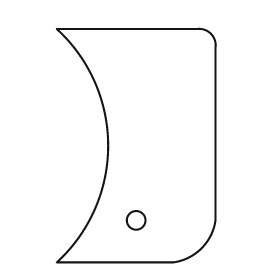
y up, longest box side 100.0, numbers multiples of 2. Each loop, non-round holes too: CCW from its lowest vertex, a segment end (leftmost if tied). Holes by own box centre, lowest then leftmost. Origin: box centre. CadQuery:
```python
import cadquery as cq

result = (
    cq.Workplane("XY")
    .moveTo(-34.0, -50.0)
    .lineTo(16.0, -50.0)
    .threePointArc((28.0, -44.0), (34.0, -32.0))
    .lineTo(34.0, 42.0)
    .threePointArc((32.0, 48.0), (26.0, 50.0))
    .lineTo(-34.0, 50.0)
    .threePointArc((-12.0, 0.0), (-34.0, -50.0))
    .close()
    .moveTo(0.0, -32.0)
    .circle(4.0)
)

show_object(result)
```